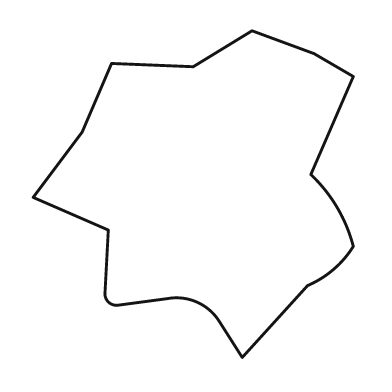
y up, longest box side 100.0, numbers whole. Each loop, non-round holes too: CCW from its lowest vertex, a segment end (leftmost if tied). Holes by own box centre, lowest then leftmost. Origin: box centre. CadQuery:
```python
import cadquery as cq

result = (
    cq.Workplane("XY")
    .moveTo(15.0, -50.0)
    .lineTo(35.0, -28.0)
    .threePointArc((43.0, -23.0), (49.0, -16.0))
    .threePointArc((44.0, -4.0), (36.0, 6.0))
    .lineTo(49.0, 36.0)
    .lineTo(37.0, 43.0)
    .lineTo(18.0, 50.0)
    .lineTo(0.0, 39.0)
    .lineTo(-25.0, 40.0)
    .lineTo(-34.0, 19.0)
    .lineTo(-49.0, -1.0)
    .lineTo(-26.0, -11.0)
    .lineTo(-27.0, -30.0)
    .threePointArc((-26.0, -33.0), (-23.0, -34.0))
    .lineTo(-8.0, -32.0)
    .threePointArc((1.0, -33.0), (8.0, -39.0))
    .close()
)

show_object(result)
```